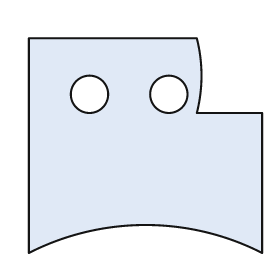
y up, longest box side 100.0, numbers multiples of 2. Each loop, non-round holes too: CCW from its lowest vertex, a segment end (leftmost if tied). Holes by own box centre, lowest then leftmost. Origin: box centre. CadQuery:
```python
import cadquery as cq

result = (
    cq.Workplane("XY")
    .moveTo(-50.0, -46.0)
    .threePointArc((0.0, -34.0), (50.0, -46.0))
    .lineTo(50.0, 14.0)
    .lineTo(22.0, 14.0)
    .threePointArc((24.0, 30.0), (22.0, 46.0))
    .lineTo(-50.0, 46.0)
    .close()
    .moveTo(-24.0, 22.0)
    .circle(8.0)
    .moveTo(10.0, 22.0)
    .circle(8.0)
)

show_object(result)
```